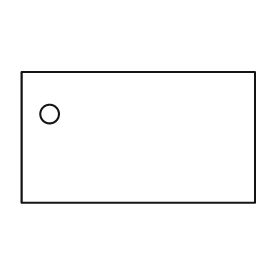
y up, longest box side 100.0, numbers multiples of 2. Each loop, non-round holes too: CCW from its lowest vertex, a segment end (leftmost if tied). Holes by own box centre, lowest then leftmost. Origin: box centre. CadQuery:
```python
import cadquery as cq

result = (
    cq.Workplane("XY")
    .moveTo(-50.0, -28.0)
    .lineTo(50.0, -28.0)
    .lineTo(50.0, 28.0)
    .lineTo(-50.0, 28.0)
    .close()
    .moveTo(-38.0, 10.0)
    .circle(4.0)
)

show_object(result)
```